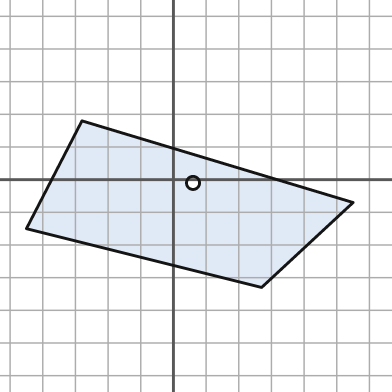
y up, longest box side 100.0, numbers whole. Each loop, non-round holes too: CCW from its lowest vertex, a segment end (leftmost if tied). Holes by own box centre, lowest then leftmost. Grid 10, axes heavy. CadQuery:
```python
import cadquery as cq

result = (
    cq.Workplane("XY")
    .moveTo(27.0, -33.0)
    .lineTo(55.0, -7.0)
    .lineTo(-28.0, 18.0)
    .lineTo(-45.0, -15.0)
    .close()
    .moveTo(6.0, -1.0)
    .circle(2.0)
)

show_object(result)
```